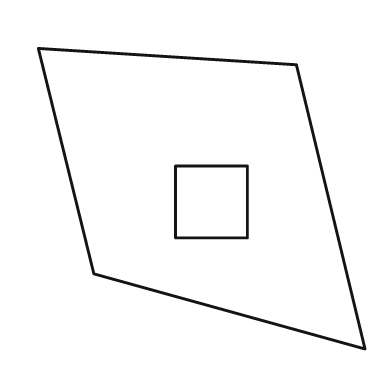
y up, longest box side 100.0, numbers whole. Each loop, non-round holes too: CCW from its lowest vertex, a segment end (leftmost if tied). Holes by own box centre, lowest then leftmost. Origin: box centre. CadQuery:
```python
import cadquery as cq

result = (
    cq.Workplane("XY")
    .moveTo(50.0, -46.0)
    .lineTo(29.0, 41.0)
    .lineTo(-50.0, 46.0)
    .lineTo(-33.0, -23.0)
    .close()
    .moveTo(-8.0, -12.0)
    .lineTo(14.0, -12.0)
    .lineTo(14.0, 10.0)
    .lineTo(-8.0, 10.0)
    .close()
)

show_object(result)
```